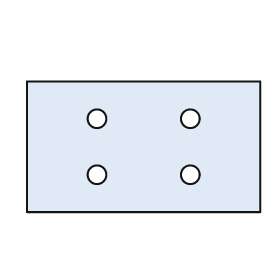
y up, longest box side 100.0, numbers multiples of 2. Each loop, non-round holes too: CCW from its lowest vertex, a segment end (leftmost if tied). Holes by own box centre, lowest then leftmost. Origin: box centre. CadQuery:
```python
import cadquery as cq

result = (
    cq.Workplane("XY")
    .moveTo(-50.0, -28.0)
    .lineTo(50.0, -28.0)
    .lineTo(50.0, 28.0)
    .lineTo(-50.0, 28.0)
    .close()
    .moveTo(-20.0, -12.0)
    .circle(4.0)
    .moveTo(20.0, -12.0)
    .circle(4.0)
    .moveTo(-20.0, 12.0)
    .circle(4.0)
    .moveTo(20.0, 12.0)
    .circle(4.0)
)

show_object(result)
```